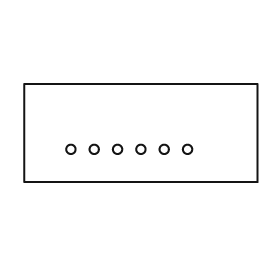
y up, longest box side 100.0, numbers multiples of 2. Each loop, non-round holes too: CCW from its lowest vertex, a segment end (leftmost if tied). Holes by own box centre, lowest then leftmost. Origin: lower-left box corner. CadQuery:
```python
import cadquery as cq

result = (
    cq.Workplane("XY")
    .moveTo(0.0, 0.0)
    .lineTo(100.0, 0.0)
    .lineTo(100.0, 42.0)
    .lineTo(0.0, 42.0)
    .close()
    .moveTo(20.0, 14.0)
    .circle(2.0)
    .moveTo(30.0, 14.0)
    .circle(2.0)
    .moveTo(40.0, 14.0)
    .circle(2.0)
    .moveTo(50.0, 14.0)
    .circle(2.0)
    .moveTo(60.0, 14.0)
    .circle(2.0)
    .moveTo(70.0, 14.0)
    .circle(2.0)
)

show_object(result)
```